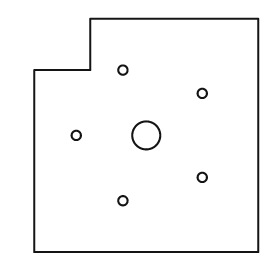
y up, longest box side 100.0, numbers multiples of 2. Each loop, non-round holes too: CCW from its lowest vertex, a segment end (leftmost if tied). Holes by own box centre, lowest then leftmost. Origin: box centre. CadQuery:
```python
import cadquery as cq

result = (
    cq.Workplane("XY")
    .moveTo(-48.0, -50.0)
    .lineTo(48.0, -50.0)
    .lineTo(48.0, 50.0)
    .lineTo(-24.0, 50.0)
    .lineTo(-24.0, 28.0)
    .lineTo(-48.0, 28.0)
    .close()
    .moveTo(-10.0, -28.0)
    .circle(2.0)
    .moveTo(24.0, -18.0)
    .circle(2.0)
    .moveTo(-30.0, 0.0)
    .circle(2.0)
    .moveTo(0.0, 0.0)
    .circle(6.0)
    .moveTo(24.0, 18.0)
    .circle(2.0)
    .moveTo(-10.0, 28.0)
    .circle(2.0)
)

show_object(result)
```